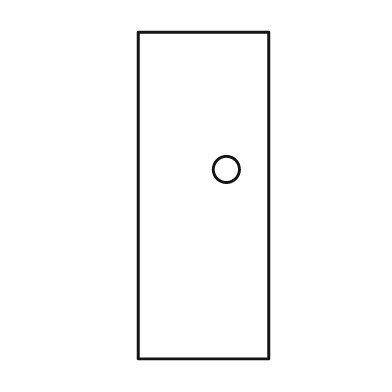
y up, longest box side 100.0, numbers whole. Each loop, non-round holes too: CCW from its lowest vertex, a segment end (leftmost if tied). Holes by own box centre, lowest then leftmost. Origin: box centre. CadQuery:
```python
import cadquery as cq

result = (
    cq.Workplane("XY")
    .moveTo(-20.0, -50.0)
    .lineTo(20.0, -50.0)
    .lineTo(20.0, 50.0)
    .lineTo(-20.0, 50.0)
    .close()
    .moveTo(7.0, 8.0)
    .circle(4.0)
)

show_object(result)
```